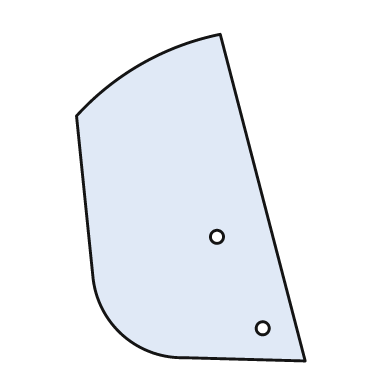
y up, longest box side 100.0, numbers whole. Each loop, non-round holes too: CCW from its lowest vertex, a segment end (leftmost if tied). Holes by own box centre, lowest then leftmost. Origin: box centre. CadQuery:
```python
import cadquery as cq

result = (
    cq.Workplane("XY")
    .moveTo(35.0, -50.0)
    .lineTo(9.0, 50.0)
    .threePointArc((-15.0, 41.0), (-35.0, 25.0))
    .lineTo(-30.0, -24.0)
    .threePointArc((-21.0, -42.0), (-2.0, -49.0))
    .close()
    .moveTo(22.0, -40.0)
    .circle(2.0)
    .moveTo(8.0, -12.0)
    .circle(2.0)
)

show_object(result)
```